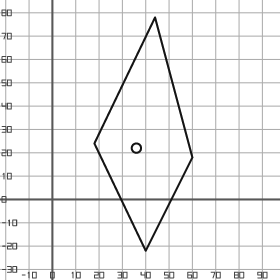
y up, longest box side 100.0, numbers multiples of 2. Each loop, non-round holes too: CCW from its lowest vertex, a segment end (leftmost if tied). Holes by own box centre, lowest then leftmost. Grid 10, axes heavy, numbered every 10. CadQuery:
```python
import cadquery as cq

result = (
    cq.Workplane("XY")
    .moveTo(40.0, -22.0)
    .lineTo(60.0, 18.0)
    .lineTo(44.0, 78.0)
    .lineTo(18.0, 24.0)
    .close()
    .moveTo(36.0, 22.0)
    .circle(2.0)
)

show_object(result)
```